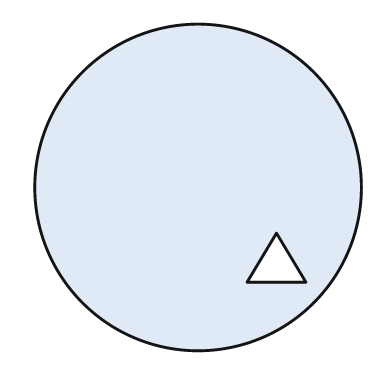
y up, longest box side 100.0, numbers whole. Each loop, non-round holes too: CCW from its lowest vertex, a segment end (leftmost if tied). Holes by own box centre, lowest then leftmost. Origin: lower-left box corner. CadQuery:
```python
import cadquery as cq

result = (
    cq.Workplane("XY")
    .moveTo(50.0, 50.0)
    .circle(50.0)
    .moveTo(65.0, 21.0)
    .lineTo(83.0, 21.0)
    .lineTo(74.0, 36.0)
    .close()
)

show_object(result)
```